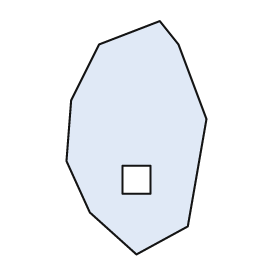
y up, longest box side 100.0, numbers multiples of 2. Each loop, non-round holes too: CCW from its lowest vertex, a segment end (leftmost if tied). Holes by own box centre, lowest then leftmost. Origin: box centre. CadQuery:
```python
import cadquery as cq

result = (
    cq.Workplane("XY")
    .moveTo(0.0, -50.0)
    .lineTo(22.0, -38.0)
    .lineTo(30.0, 8.0)
    .lineTo(18.0, 40.0)
    .lineTo(10.0, 50.0)
    .lineTo(-16.0, 40.0)
    .lineTo(-28.0, 16.0)
    .lineTo(-30.0, -10.0)
    .lineTo(-20.0, -32.0)
    .close()
    .moveTo(-6.0, -24.0)
    .lineTo(6.0, -24.0)
    .lineTo(6.0, -12.0)
    .lineTo(-6.0, -12.0)
    .close()
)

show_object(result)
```